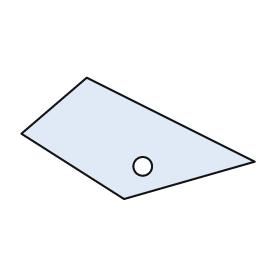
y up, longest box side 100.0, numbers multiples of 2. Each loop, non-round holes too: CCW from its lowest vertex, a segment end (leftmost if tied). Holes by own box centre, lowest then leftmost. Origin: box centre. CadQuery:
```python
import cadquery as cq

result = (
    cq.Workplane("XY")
    .moveTo(-6.0, -26.0)
    .lineTo(50.0, -10.0)
    .lineTo(-22.0, 26.0)
    .lineTo(-50.0, 2.0)
    .close()
    .moveTo(2.0, -12.0)
    .circle(4.0)
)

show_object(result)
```